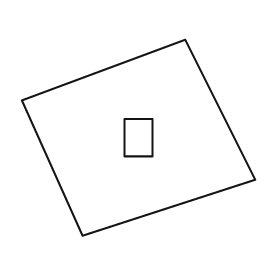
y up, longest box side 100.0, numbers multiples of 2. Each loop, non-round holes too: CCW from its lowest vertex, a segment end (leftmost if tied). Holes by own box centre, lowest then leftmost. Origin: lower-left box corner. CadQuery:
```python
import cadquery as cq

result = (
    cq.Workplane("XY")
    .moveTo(26.0, 0.0)
    .lineTo(100.0, 24.0)
    .lineTo(70.0, 84.0)
    .lineTo(0.0, 58.0)
    .close()
    .moveTo(44.0, 34.0)
    .lineTo(56.0, 34.0)
    .lineTo(56.0, 50.0)
    .lineTo(44.0, 50.0)
    .close()
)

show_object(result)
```